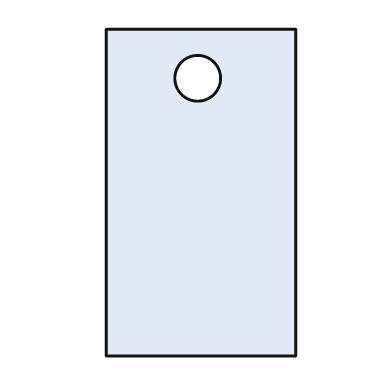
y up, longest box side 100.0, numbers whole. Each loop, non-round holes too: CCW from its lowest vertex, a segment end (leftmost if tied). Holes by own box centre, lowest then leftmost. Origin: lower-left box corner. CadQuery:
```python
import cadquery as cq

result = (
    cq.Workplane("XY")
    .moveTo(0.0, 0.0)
    .lineTo(58.0, 0.0)
    .lineTo(58.0, 100.0)
    .lineTo(0.0, 100.0)
    .close()
    .moveTo(28.0, 85.0)
    .circle(7.0)
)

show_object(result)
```